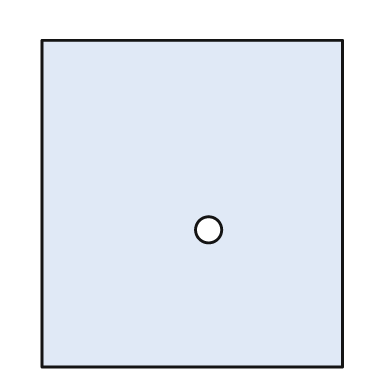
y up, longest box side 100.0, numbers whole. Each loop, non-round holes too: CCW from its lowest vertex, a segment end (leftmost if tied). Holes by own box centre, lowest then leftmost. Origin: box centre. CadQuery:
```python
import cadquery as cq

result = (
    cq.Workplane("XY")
    .moveTo(-46.0, -50.0)
    .lineTo(46.0, -50.0)
    .lineTo(46.0, 50.0)
    .lineTo(-46.0, 50.0)
    .close()
    .moveTo(5.0, -8.0)
    .circle(4.0)
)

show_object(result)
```